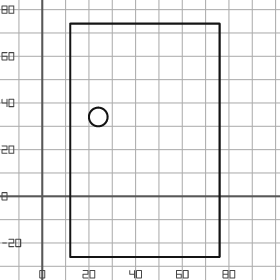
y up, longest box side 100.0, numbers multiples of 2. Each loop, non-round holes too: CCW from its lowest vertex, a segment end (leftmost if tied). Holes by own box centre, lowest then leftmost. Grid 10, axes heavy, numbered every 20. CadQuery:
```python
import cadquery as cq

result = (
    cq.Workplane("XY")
    .moveTo(12.0, -26.0)
    .lineTo(76.0, -26.0)
    .lineTo(76.0, 74.0)
    .lineTo(12.0, 74.0)
    .close()
    .moveTo(24.0, 34.0)
    .circle(4.0)
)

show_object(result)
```